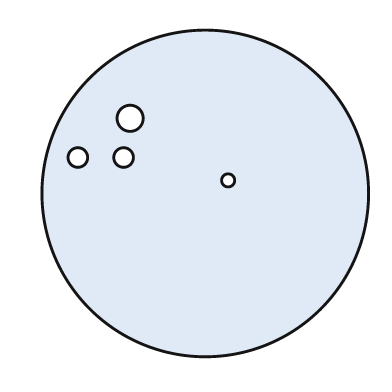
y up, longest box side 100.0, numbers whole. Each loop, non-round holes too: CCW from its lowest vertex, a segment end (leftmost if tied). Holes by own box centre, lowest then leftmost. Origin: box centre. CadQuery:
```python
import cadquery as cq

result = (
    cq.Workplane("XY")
    .moveTo(0.0, 0.0)
    .circle(50.0)
    .moveTo(7.0, 4.0)
    .circle(2.0)
    .moveTo(-39.0, 11.0)
    .circle(3.0)
    .moveTo(-25.0, 11.0)
    .circle(3.0)
    .moveTo(-23.0, 23.0)
    .circle(4.0)
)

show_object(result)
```